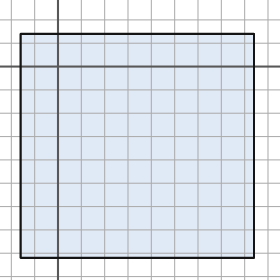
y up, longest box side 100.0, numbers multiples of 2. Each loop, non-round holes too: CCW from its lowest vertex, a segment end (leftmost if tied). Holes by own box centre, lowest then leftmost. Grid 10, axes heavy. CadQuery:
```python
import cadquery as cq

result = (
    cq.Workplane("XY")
    .moveTo(-16.0, -82.0)
    .lineTo(84.0, -82.0)
    .lineTo(84.0, 14.0)
    .lineTo(-16.0, 14.0)
    .close()
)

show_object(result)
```